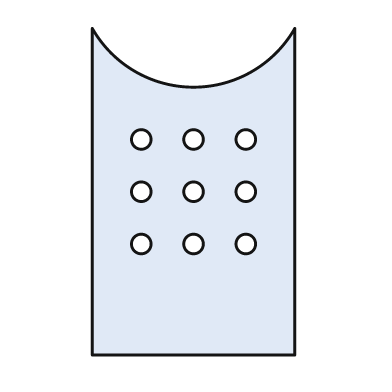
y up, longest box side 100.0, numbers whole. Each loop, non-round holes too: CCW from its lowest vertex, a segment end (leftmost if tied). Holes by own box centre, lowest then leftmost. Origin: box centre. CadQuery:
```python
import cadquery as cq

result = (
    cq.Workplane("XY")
    .moveTo(-31.0, -50.0)
    .lineTo(31.0, -50.0)
    .lineTo(31.0, 50.0)
    .threePointArc((0.0, 32.0), (-31.0, 50.0))
    .close()
    .moveTo(-16.0, -16.0)
    .circle(3.0)
    .moveTo(0.0, -16.0)
    .circle(3.0)
    .moveTo(16.0, -16.0)
    .circle(3.0)
    .moveTo(-16.0, 0.0)
    .circle(3.0)
    .moveTo(0.0, 0.0)
    .circle(3.0)
    .moveTo(16.0, 0.0)
    .circle(3.0)
    .moveTo(-16.0, 16.0)
    .circle(3.0)
    .moveTo(0.0, 16.0)
    .circle(3.0)
    .moveTo(16.0, 16.0)
    .circle(3.0)
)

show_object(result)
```